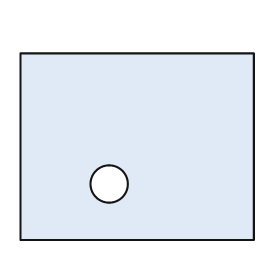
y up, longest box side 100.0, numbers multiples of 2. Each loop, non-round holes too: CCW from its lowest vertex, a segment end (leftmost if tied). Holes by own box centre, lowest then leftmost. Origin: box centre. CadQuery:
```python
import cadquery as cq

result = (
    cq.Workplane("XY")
    .moveTo(-50.0, -40.0)
    .lineTo(50.0, -40.0)
    .lineTo(50.0, 40.0)
    .lineTo(-50.0, 40.0)
    .close()
    .moveTo(-12.0, -16.0)
    .circle(8.0)
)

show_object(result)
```